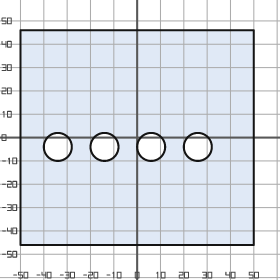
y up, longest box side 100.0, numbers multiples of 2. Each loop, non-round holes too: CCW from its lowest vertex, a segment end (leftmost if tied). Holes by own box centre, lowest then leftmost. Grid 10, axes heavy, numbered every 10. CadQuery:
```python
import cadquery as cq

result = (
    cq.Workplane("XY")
    .moveTo(-50.0, -46.0)
    .lineTo(50.0, -46.0)
    .lineTo(50.0, 46.0)
    .lineTo(-50.0, 46.0)
    .close()
    .moveTo(-34.0, -4.0)
    .circle(6.0)
    .moveTo(-14.0, -4.0)
    .circle(6.0)
    .moveTo(6.0, -4.0)
    .circle(6.0)
    .moveTo(26.0, -4.0)
    .circle(6.0)
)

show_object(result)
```